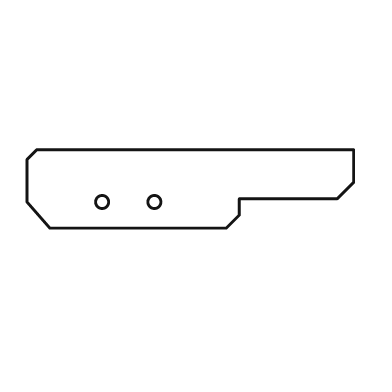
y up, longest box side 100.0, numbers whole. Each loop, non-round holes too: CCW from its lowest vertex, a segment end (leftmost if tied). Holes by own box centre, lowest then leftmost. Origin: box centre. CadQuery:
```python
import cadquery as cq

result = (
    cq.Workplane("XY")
    .moveTo(-43.0, -12.0)
    .lineTo(11.0, -12.0)
    .lineTo(15.0, -8.0)
    .lineTo(15.0, -3.0)
    .lineTo(45.0, -3.0)
    .lineTo(50.0, 2.0)
    .lineTo(50.0, 12.0)
    .lineTo(-47.0, 12.0)
    .lineTo(-50.0, 9.0)
    .lineTo(-50.0, -4.0)
    .close()
    .moveTo(-27.0, -4.0)
    .circle(2.0)
    .moveTo(-11.0, -4.0)
    .circle(2.0)
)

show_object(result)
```